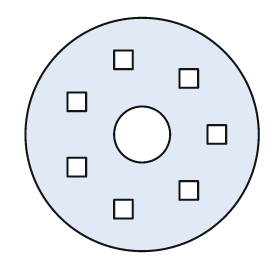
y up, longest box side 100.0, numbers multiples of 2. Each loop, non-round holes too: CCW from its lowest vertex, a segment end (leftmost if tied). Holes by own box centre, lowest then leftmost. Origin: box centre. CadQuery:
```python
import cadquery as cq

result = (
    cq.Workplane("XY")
    .moveTo(0.0, 0.0)
    .circle(50.0)
    .moveTo(-12.0, -36.0)
    .lineTo(-4.0, -36.0)
    .lineTo(-4.0, -28.0)
    .lineTo(-12.0, -28.0)
    .close()
    .moveTo(16.0, -28.0)
    .lineTo(24.0, -28.0)
    .lineTo(24.0, -20.0)
    .lineTo(16.0, -20.0)
    .close()
    .moveTo(-32.0, -18.0)
    .lineTo(-24.0, -18.0)
    .lineTo(-24.0, -10.0)
    .lineTo(-32.0, -10.0)
    .close()
    .moveTo(0.0, 0.0)
    .circle(12.0)
    .moveTo(28.0, -4.0)
    .lineTo(36.0, -4.0)
    .lineTo(36.0, 4.0)
    .lineTo(28.0, 4.0)
    .close()
    .moveTo(-32.0, 10.0)
    .lineTo(-24.0, 10.0)
    .lineTo(-24.0, 18.0)
    .lineTo(-32.0, 18.0)
    .close()
    .moveTo(16.0, 20.0)
    .lineTo(24.0, 20.0)
    .lineTo(24.0, 28.0)
    .lineTo(16.0, 28.0)
    .close()
    .moveTo(-12.0, 28.0)
    .lineTo(-4.0, 28.0)
    .lineTo(-4.0, 36.0)
    .lineTo(-12.0, 36.0)
    .close()
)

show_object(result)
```